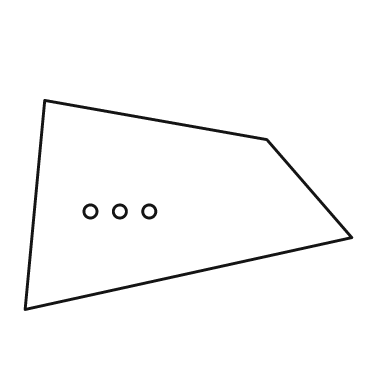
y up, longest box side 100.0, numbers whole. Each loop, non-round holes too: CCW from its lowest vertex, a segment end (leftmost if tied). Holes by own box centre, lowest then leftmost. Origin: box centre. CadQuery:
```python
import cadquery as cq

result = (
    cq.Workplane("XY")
    .moveTo(-50.0, -32.0)
    .lineTo(50.0, -10.0)
    .lineTo(24.0, 20.0)
    .lineTo(-44.0, 32.0)
    .close()
    .moveTo(-30.0, -2.0)
    .circle(2.0)
    .moveTo(-21.0, -2.0)
    .circle(2.0)
    .moveTo(-12.0, -2.0)
    .circle(2.0)
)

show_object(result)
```